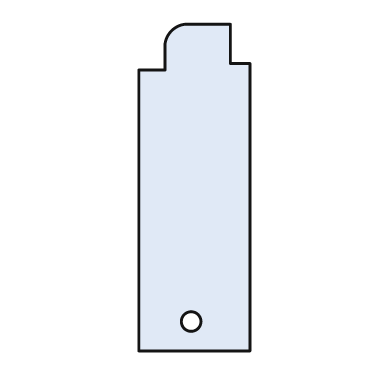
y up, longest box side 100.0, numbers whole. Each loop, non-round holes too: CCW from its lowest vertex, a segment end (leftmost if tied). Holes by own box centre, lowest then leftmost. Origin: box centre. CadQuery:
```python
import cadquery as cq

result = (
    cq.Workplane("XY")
    .moveTo(-17.0, -50.0)
    .lineTo(17.0, -50.0)
    .lineTo(17.0, 38.0)
    .lineTo(11.0, 38.0)
    .lineTo(11.0, 50.0)
    .lineTo(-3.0, 50.0)
    .threePointArc((-7.0, 48.0), (-9.0, 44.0))
    .lineTo(-9.0, 36.0)
    .lineTo(-17.0, 36.0)
    .close()
    .moveTo(-1.0, -41.0)
    .circle(3.0)
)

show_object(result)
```